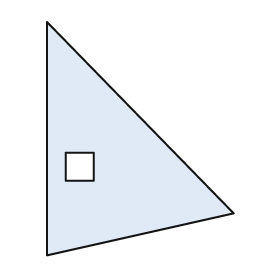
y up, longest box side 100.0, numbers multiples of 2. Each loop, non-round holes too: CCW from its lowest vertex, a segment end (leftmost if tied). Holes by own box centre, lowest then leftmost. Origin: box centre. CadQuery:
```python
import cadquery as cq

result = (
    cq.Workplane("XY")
    .moveTo(-40.0, -50.0)
    .lineTo(40.0, -32.0)
    .lineTo(-40.0, 50.0)
    .close()
    .moveTo(-32.0, -18.0)
    .lineTo(-20.0, -18.0)
    .lineTo(-20.0, -6.0)
    .lineTo(-32.0, -6.0)
    .close()
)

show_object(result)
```